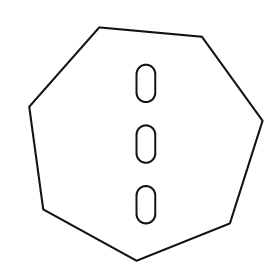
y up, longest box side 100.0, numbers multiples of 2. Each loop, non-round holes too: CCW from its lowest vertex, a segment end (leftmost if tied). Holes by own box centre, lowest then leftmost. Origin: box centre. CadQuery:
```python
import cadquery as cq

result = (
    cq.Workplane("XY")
    .moveTo(-4.0, -50.0)
    .lineTo(36.0, -34.0)
    .lineTo(50.0, 10.0)
    .lineTo(24.0, 46.0)
    .lineTo(-20.0, 50.0)
    .lineTo(-50.0, 16.0)
    .lineTo(-44.0, -28.0)
    .close()
    .moveTo(-4.0, -30.0)
    .threePointArc((0.0, -34.0), (4.0, -30.0))
    .lineTo(4.0, -22.0)
    .threePointArc((0.0, -18.0), (-4.0, -22.0))
    .close()
    .moveTo(-4.0, -4.0)
    .threePointArc((0.0, -8.0), (4.0, -4.0))
    .lineTo(4.0, 4.0)
    .threePointArc((0.0, 8.0), (-4.0, 4.0))
    .close()
    .moveTo(-4.0, 22.0)
    .threePointArc((0.0, 18.0), (4.0, 22.0))
    .lineTo(4.0, 30.0)
    .threePointArc((0.0, 34.0), (-4.0, 30.0))
    .close()
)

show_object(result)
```